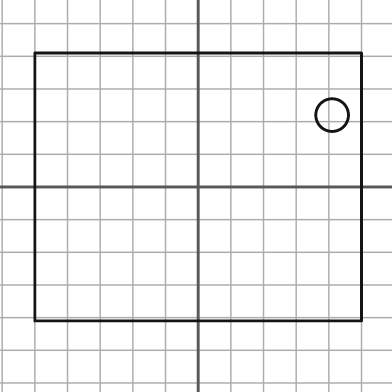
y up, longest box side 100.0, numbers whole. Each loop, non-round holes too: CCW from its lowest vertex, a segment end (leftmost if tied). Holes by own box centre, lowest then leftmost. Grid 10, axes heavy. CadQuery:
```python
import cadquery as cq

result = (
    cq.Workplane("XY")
    .moveTo(-50.0, -41.0)
    .lineTo(50.0, -41.0)
    .lineTo(50.0, 41.0)
    .lineTo(-50.0, 41.0)
    .close()
    .moveTo(41.0, 22.0)
    .circle(5.0)
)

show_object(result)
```